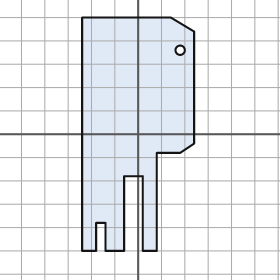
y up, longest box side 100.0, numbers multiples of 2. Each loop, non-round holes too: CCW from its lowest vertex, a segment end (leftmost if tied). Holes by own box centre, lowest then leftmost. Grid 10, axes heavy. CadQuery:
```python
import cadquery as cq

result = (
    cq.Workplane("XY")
    .moveTo(-24.0, -50.0)
    .lineTo(-18.0, -50.0)
    .lineTo(-18.0, -38.0)
    .lineTo(-14.0, -38.0)
    .lineTo(-14.0, -50.0)
    .lineTo(-6.0, -50.0)
    .lineTo(-6.0, -18.0)
    .lineTo(2.0, -18.0)
    .lineTo(2.0, -50.0)
    .lineTo(8.0, -50.0)
    .lineTo(8.0, -8.0)
    .lineTo(18.0, -8.0)
    .lineTo(24.0, -4.0)
    .lineTo(24.0, 44.0)
    .lineTo(14.0, 50.0)
    .lineTo(-24.0, 50.0)
    .close()
    .moveTo(18.0, 36.0)
    .circle(2.0)
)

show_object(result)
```